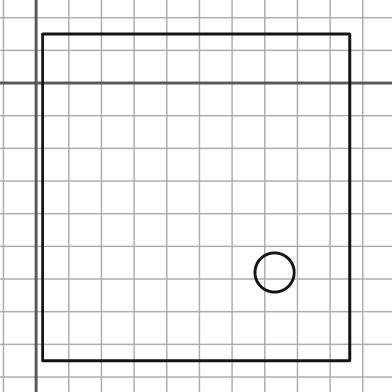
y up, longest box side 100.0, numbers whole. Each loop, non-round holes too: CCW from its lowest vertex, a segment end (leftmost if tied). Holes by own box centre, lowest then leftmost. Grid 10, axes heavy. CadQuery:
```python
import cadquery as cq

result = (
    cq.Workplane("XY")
    .moveTo(2.0, -85.0)
    .lineTo(96.0, -85.0)
    .lineTo(96.0, 15.0)
    .lineTo(2.0, 15.0)
    .close()
    .moveTo(73.0, -58.0)
    .circle(6.0)
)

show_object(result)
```